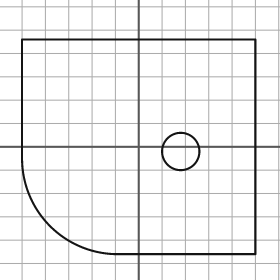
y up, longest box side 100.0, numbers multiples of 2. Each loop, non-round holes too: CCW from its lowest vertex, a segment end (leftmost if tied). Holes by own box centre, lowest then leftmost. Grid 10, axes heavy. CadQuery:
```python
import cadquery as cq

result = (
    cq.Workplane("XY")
    .moveTo(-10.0, -46.0)
    .lineTo(50.0, -46.0)
    .lineTo(50.0, 46.0)
    .lineTo(-50.0, 46.0)
    .lineTo(-50.0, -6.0)
    .threePointArc((-38.0, -34.0), (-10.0, -46.0))
    .close()
    .moveTo(18.0, -2.0)
    .circle(8.0)
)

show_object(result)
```